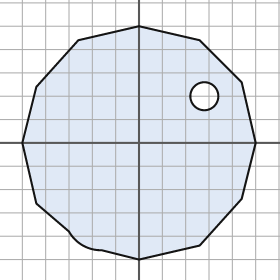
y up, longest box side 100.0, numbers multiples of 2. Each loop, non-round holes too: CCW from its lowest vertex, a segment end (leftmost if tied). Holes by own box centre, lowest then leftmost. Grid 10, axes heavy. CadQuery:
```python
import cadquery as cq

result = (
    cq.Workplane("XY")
    .moveTo(0.0, -50.0)
    .lineTo(26.0, -44.0)
    .lineTo(44.0, -24.0)
    .lineTo(50.0, 0.0)
    .lineTo(44.0, 26.0)
    .lineTo(26.0, 44.0)
    .lineTo(0.0, 50.0)
    .lineTo(-26.0, 44.0)
    .lineTo(-44.0, 24.0)
    .lineTo(-50.0, 0.0)
    .lineTo(-44.0, -26.0)
    .lineTo(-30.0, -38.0)
    .threePointArc((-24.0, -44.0), (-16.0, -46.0))
    .close()
    .moveTo(28.0, 20.0)
    .circle(6.0)
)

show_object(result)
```